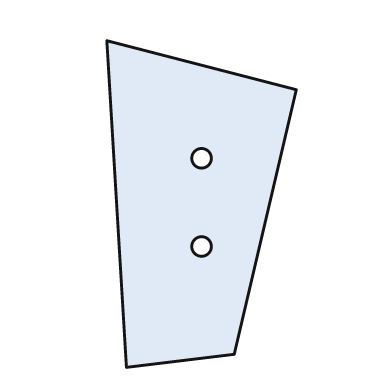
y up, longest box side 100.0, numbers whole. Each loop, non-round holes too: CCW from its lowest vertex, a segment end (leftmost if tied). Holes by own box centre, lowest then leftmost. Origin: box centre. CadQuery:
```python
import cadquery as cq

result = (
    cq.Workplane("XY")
    .moveTo(-23.0, -50.0)
    .lineTo(10.0, -46.0)
    .lineTo(29.0, 35.0)
    .lineTo(-29.0, 50.0)
    .close()
    .moveTo(0.0, -13.0)
    .circle(3.0)
    .moveTo(0.0, 14.0)
    .circle(3.0)
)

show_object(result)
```